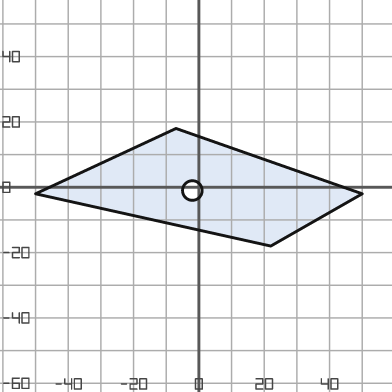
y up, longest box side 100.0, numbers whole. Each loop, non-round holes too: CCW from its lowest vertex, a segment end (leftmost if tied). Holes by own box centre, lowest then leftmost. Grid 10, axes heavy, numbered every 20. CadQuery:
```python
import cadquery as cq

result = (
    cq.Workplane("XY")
    .moveTo(22.0, -18.0)
    .lineTo(50.0, -2.0)
    .lineTo(-7.0, 18.0)
    .lineTo(-50.0, -2.0)
    .close()
    .moveTo(-2.0, -1.0)
    .circle(3.0)
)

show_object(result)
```